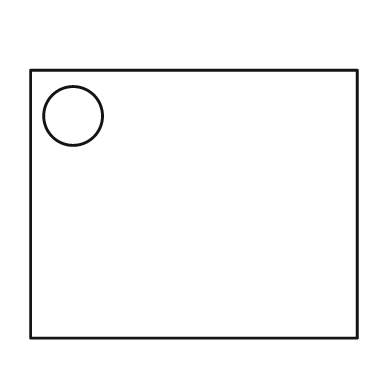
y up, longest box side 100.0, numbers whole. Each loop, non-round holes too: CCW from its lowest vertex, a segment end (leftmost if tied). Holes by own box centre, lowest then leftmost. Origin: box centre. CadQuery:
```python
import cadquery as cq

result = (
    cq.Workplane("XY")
    .moveTo(-50.0, -41.0)
    .lineTo(50.0, -41.0)
    .lineTo(50.0, 41.0)
    .lineTo(-50.0, 41.0)
    .close()
    .moveTo(-37.0, 27.0)
    .circle(9.0)
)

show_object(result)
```